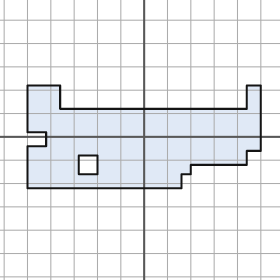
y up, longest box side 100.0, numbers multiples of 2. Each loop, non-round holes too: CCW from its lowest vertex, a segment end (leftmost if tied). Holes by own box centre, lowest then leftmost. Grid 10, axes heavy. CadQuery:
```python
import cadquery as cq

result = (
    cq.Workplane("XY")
    .moveTo(-50.0, -22.0)
    .lineTo(16.0, -22.0)
    .lineTo(16.0, -16.0)
    .lineTo(20.0, -16.0)
    .lineTo(20.0, -12.0)
    .lineTo(44.0, -12.0)
    .lineTo(44.0, -6.0)
    .lineTo(50.0, -6.0)
    .lineTo(50.0, 22.0)
    .lineTo(44.0, 22.0)
    .lineTo(44.0, 12.0)
    .lineTo(-36.0, 12.0)
    .lineTo(-36.0, 22.0)
    .lineTo(-50.0, 22.0)
    .lineTo(-50.0, 2.0)
    .lineTo(-42.0, 2.0)
    .lineTo(-42.0, -4.0)
    .lineTo(-50.0, -4.0)
    .close()
    .moveTo(-28.0, -16.0)
    .lineTo(-20.0, -16.0)
    .lineTo(-20.0, -8.0)
    .lineTo(-28.0, -8.0)
    .close()
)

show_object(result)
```